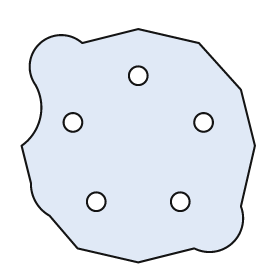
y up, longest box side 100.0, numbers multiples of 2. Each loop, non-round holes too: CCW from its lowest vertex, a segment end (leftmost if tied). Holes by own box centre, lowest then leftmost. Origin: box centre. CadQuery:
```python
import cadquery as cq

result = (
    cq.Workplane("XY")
    .moveTo(0.0, -50.0)
    .lineTo(24.0, -44.0)
    .threePointArc((40.0, -42.0), (44.0, -26.0))
    .lineTo(50.0, 0.0)
    .lineTo(44.0, 24.0)
    .lineTo(26.0, 44.0)
    .lineTo(0.0, 50.0)
    .lineTo(-24.0, 44.0)
    .threePointArc((-42.0, 44.0), (-44.0, 26.0))
    .threePointArc((-42.0, 12.0), (-50.0, 0.0))
    .lineTo(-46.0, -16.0)
    .threePointArc((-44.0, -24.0), (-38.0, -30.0))
    .lineTo(-26.0, -44.0)
    .close()
    .moveTo(-18.0, -24.0)
    .circle(4.0)
    .moveTo(18.0, -24.0)
    .circle(4.0)
    .moveTo(-28.0, 10.0)
    .circle(4.0)
    .moveTo(28.0, 10.0)
    .circle(4.0)
    .moveTo(0.0, 30.0)
    .circle(4.0)
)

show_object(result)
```